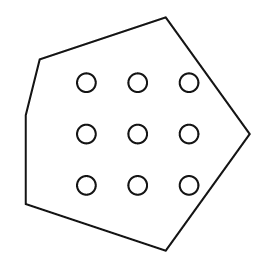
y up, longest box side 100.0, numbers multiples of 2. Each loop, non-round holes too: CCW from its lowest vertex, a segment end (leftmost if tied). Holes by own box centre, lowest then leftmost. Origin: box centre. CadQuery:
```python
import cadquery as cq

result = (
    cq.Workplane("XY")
    .moveTo(12.0, -50.0)
    .lineTo(48.0, 0.0)
    .lineTo(12.0, 50.0)
    .lineTo(-42.0, 32.0)
    .lineTo(-48.0, 8.0)
    .lineTo(-48.0, -30.0)
    .close()
    .moveTo(-22.0, -22.0)
    .circle(4.0)
    .moveTo(0.0, -22.0)
    .circle(4.0)
    .moveTo(22.0, -22.0)
    .circle(4.0)
    .moveTo(-22.0, 0.0)
    .circle(4.0)
    .moveTo(0.0, 0.0)
    .circle(4.0)
    .moveTo(22.0, 0.0)
    .circle(4.0)
    .moveTo(-22.0, 22.0)
    .circle(4.0)
    .moveTo(0.0, 22.0)
    .circle(4.0)
    .moveTo(22.0, 22.0)
    .circle(4.0)
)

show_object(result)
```